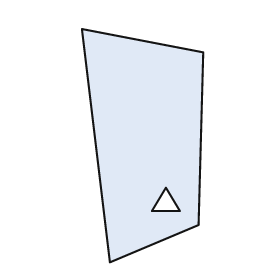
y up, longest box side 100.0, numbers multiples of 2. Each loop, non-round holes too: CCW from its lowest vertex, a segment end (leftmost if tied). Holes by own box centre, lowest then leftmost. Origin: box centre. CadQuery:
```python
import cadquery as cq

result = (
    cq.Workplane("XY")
    .moveTo(-14.0, -50.0)
    .lineTo(24.0, -34.0)
    .lineTo(26.0, 40.0)
    .lineTo(-26.0, 50.0)
    .close()
    .moveTo(4.0, -28.0)
    .lineTo(16.0, -28.0)
    .lineTo(10.0, -18.0)
    .close()
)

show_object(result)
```